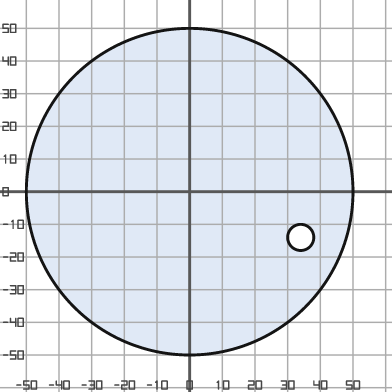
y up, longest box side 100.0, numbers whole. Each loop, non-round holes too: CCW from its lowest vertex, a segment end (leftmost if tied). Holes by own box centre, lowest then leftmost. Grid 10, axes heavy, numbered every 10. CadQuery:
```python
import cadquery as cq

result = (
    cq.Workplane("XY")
    .moveTo(0.0, 0.0)
    .circle(50.0)
    .moveTo(34.0, -14.0)
    .circle(4.0)
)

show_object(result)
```